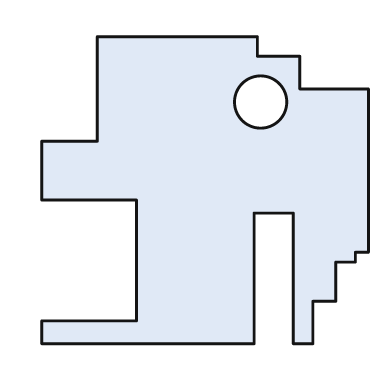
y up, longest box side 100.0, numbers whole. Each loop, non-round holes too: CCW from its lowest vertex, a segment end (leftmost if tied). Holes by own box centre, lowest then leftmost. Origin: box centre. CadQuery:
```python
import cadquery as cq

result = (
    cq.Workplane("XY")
    .moveTo(-50.0, -47.0)
    .lineTo(15.0, -47.0)
    .lineTo(15.0, -7.0)
    .lineTo(27.0, -7.0)
    .lineTo(27.0, -47.0)
    .lineTo(33.0, -47.0)
    .lineTo(33.0, -34.0)
    .lineTo(40.0, -34.0)
    .lineTo(40.0, -22.0)
    .lineTo(46.0, -22.0)
    .lineTo(46.0, -19.0)
    .lineTo(50.0, -19.0)
    .lineTo(50.0, 31.0)
    .lineTo(29.0, 31.0)
    .lineTo(29.0, 41.0)
    .lineTo(16.0, 41.0)
    .lineTo(16.0, 47.0)
    .lineTo(-33.0, 47.0)
    .lineTo(-33.0, 15.0)
    .lineTo(-50.0, 15.0)
    .lineTo(-50.0, -3.0)
    .lineTo(-21.0, -3.0)
    .lineTo(-21.0, -40.0)
    .lineTo(-50.0, -40.0)
    .close()
    .moveTo(17.0, 27.0)
    .circle(8.0)
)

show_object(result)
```